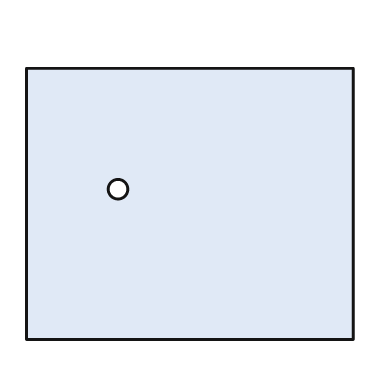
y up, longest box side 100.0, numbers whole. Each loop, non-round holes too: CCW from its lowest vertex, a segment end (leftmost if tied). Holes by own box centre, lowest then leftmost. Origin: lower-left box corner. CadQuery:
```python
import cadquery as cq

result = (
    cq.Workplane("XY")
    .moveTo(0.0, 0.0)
    .lineTo(100.0, 0.0)
    .lineTo(100.0, 83.0)
    .lineTo(0.0, 83.0)
    .close()
    .moveTo(28.0, 46.0)
    .circle(3.0)
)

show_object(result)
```